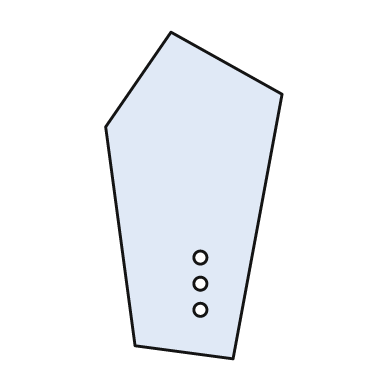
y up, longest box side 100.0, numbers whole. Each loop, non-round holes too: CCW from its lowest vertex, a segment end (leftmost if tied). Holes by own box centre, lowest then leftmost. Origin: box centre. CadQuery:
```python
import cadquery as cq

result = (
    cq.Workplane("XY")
    .moveTo(12.0, -50.0)
    .lineTo(27.0, 31.0)
    .lineTo(-7.0, 50.0)
    .lineTo(-27.0, 21.0)
    .lineTo(-18.0, -46.0)
    .close()
    .moveTo(2.0, -35.0)
    .circle(2.0)
    .moveTo(2.0, -27.0)
    .circle(2.0)
    .moveTo(2.0, -19.0)
    .circle(2.0)
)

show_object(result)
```